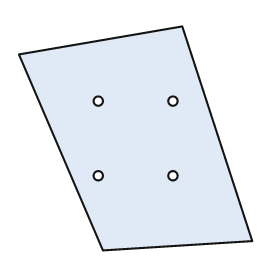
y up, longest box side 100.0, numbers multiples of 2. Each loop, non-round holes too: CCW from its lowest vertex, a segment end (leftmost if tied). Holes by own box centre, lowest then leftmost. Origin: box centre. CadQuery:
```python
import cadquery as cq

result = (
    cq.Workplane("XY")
    .moveTo(-14.0, -48.0)
    .lineTo(50.0, -44.0)
    .lineTo(20.0, 48.0)
    .lineTo(-50.0, 36.0)
    .close()
    .moveTo(-16.0, -16.0)
    .circle(2.0)
    .moveTo(16.0, -16.0)
    .circle(2.0)
    .moveTo(-16.0, 16.0)
    .circle(2.0)
    .moveTo(16.0, 16.0)
    .circle(2.0)
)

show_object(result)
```